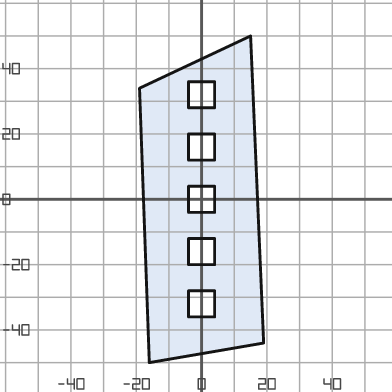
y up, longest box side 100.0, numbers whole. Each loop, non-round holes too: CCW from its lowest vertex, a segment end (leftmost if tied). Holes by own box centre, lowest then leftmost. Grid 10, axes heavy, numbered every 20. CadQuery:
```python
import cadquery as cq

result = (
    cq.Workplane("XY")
    .moveTo(-16.0, -50.0)
    .lineTo(19.0, -44.0)
    .lineTo(15.0, 50.0)
    .lineTo(-19.0, 34.0)
    .close()
    .moveTo(-4.0, -36.0)
    .lineTo(4.0, -36.0)
    .lineTo(4.0, -28.0)
    .lineTo(-4.0, -28.0)
    .close()
    .moveTo(-4.0, -20.0)
    .lineTo(4.0, -20.0)
    .lineTo(4.0, -12.0)
    .lineTo(-4.0, -12.0)
    .close()
    .moveTo(-4.0, -4.0)
    .lineTo(4.0, -4.0)
    .lineTo(4.0, 4.0)
    .lineTo(-4.0, 4.0)
    .close()
    .moveTo(-4.0, 12.0)
    .lineTo(4.0, 12.0)
    .lineTo(4.0, 20.0)
    .lineTo(-4.0, 20.0)
    .close()
    .moveTo(-4.0, 28.0)
    .lineTo(4.0, 28.0)
    .lineTo(4.0, 36.0)
    .lineTo(-4.0, 36.0)
    .close()
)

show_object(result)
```